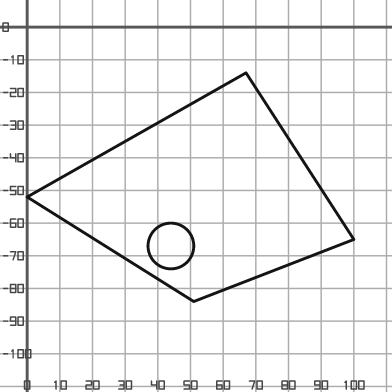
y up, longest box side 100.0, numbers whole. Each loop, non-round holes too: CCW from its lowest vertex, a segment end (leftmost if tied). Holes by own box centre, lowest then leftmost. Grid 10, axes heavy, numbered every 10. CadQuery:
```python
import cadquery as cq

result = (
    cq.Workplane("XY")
    .moveTo(51.0, -84.0)
    .lineTo(100.0, -65.0)
    .lineTo(67.0, -14.0)
    .lineTo(0.0, -52.0)
    .close()
    .moveTo(44.0, -67.0)
    .circle(7.0)
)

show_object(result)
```